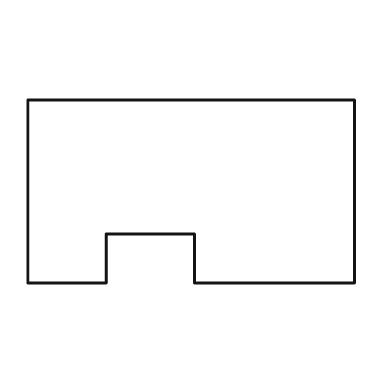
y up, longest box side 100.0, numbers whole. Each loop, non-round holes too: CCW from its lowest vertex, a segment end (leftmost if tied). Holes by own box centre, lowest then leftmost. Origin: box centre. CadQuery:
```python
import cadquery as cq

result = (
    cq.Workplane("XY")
    .moveTo(-50.0, -28.0)
    .lineTo(-26.0, -28.0)
    .lineTo(-26.0, -13.0)
    .lineTo(1.0, -13.0)
    .lineTo(1.0, -28.0)
    .lineTo(50.0, -28.0)
    .lineTo(50.0, 28.0)
    .lineTo(-50.0, 28.0)
    .close()
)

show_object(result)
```